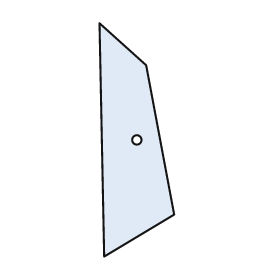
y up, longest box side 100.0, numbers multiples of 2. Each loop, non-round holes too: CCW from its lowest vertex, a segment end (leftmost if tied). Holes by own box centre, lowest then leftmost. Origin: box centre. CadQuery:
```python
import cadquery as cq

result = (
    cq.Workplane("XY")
    .moveTo(-14.0, -50.0)
    .lineTo(16.0, -32.0)
    .lineTo(4.0, 32.0)
    .lineTo(-16.0, 50.0)
    .close()
    .moveTo(0.0, 0.0)
    .circle(2.0)
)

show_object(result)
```